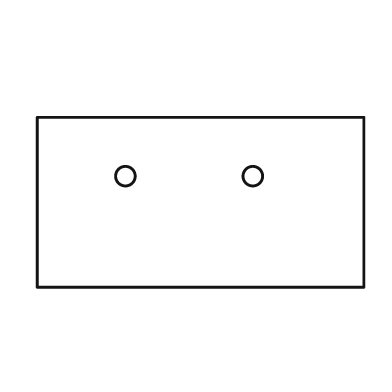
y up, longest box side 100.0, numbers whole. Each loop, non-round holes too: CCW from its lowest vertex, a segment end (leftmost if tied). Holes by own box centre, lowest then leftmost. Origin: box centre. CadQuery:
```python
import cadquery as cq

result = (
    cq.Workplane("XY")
    .moveTo(-50.0, -26.0)
    .lineTo(50.0, -26.0)
    .lineTo(50.0, 26.0)
    .lineTo(-50.0, 26.0)
    .close()
    .moveTo(-23.0, 8.0)
    .circle(3.0)
    .moveTo(16.0, 8.0)
    .circle(3.0)
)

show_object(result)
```